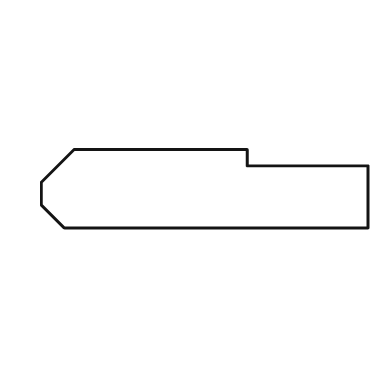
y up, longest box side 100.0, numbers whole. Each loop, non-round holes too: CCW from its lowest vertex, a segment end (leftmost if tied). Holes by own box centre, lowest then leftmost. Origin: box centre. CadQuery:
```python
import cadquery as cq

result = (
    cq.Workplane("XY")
    .moveTo(-43.0, -12.0)
    .lineTo(50.0, -12.0)
    .lineTo(50.0, 7.0)
    .lineTo(13.0, 7.0)
    .lineTo(13.0, 12.0)
    .lineTo(-40.0, 12.0)
    .lineTo(-50.0, 2.0)
    .lineTo(-50.0, -5.0)
    .close()
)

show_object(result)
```